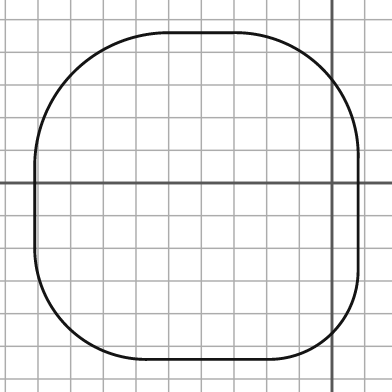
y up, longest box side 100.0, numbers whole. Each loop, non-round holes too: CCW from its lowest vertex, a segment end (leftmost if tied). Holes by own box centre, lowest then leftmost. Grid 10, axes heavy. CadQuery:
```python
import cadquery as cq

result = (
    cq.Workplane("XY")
    .moveTo(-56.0, -54.0)
    .lineTo(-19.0, -54.0)
    .threePointArc((0.0, -46.0), (8.0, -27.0))
    .lineTo(8.0, 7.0)
    .threePointArc((-3.0, 35.0), (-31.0, 46.0))
    .lineTo(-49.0, 46.0)
    .threePointArc((-79.0, 34.0), (-91.0, 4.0))
    .lineTo(-91.0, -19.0)
    .threePointArc((-81.0, -44.0), (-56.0, -54.0))
    .close()
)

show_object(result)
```